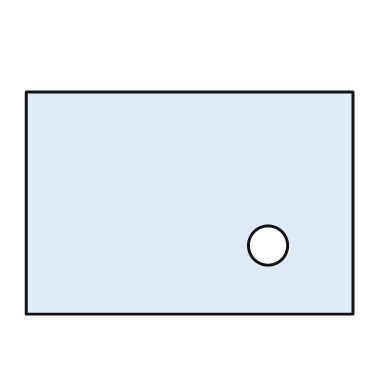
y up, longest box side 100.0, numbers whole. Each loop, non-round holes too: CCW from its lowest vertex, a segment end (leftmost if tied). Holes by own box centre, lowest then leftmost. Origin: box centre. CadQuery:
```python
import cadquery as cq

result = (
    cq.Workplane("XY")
    .moveTo(-50.0, -34.0)
    .lineTo(50.0, -34.0)
    .lineTo(50.0, 34.0)
    .lineTo(-50.0, 34.0)
    .close()
    .moveTo(24.0, -13.0)
    .circle(6.0)
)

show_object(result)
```